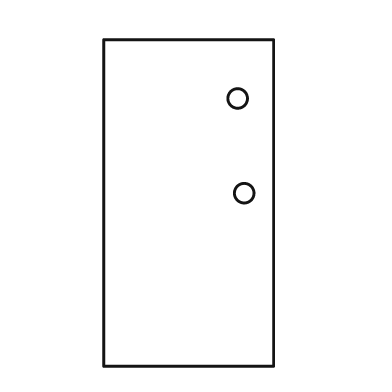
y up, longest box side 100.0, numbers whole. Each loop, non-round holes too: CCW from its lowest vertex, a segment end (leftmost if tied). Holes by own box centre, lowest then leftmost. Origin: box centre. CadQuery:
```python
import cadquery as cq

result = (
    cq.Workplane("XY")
    .moveTo(-26.0, -50.0)
    .lineTo(26.0, -50.0)
    .lineTo(26.0, 50.0)
    .lineTo(-26.0, 50.0)
    .close()
    .moveTo(17.0, 3.0)
    .circle(3.0)
    .moveTo(15.0, 32.0)
    .circle(3.0)
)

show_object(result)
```